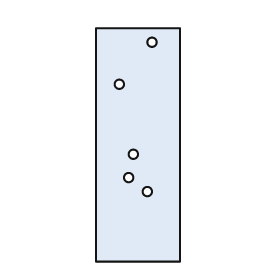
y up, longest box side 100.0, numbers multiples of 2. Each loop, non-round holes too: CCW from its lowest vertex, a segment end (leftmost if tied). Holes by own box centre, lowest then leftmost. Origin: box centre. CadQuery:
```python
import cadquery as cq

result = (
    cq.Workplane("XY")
    .moveTo(-18.0, -50.0)
    .lineTo(18.0, -50.0)
    .lineTo(18.0, 50.0)
    .lineTo(-18.0, 50.0)
    .close()
    .moveTo(4.0, -20.0)
    .circle(2.0)
    .moveTo(-4.0, -14.0)
    .circle(2.0)
    .moveTo(-2.0, -4.0)
    .circle(2.0)
    .moveTo(-8.0, 26.0)
    .circle(2.0)
    .moveTo(6.0, 44.0)
    .circle(2.0)
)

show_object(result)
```